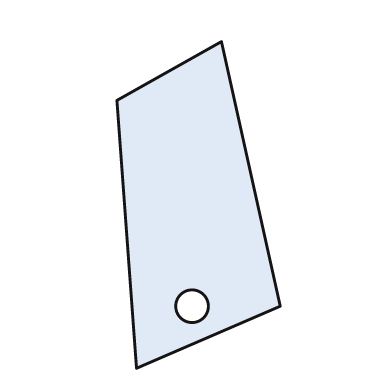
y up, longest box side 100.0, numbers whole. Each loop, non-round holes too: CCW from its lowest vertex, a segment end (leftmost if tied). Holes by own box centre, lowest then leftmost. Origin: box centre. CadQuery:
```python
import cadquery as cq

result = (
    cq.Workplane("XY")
    .moveTo(-19.0, -50.0)
    .lineTo(25.0, -31.0)
    .lineTo(7.0, 50.0)
    .lineTo(-25.0, 32.0)
    .close()
    .moveTo(-2.0, -31.0)
    .circle(5.0)
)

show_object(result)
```